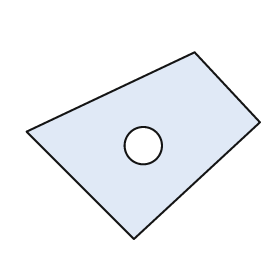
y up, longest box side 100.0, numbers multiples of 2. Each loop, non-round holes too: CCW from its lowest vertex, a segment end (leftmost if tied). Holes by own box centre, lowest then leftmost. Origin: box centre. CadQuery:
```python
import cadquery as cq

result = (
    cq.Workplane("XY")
    .moveTo(-4.0, -40.0)
    .lineTo(50.0, 10.0)
    .lineTo(22.0, 40.0)
    .lineTo(-50.0, 6.0)
    .close()
    .moveTo(0.0, 0.0)
    .circle(8.0)
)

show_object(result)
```